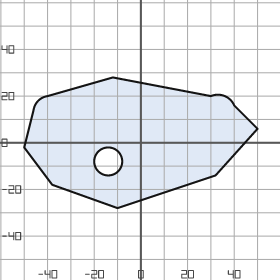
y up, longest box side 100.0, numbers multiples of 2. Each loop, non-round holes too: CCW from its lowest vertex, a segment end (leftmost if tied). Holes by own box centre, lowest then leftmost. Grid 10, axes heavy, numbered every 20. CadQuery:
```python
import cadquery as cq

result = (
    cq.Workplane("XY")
    .moveTo(-10.0, -28.0)
    .lineTo(32.0, -14.0)
    .lineTo(50.0, 6.0)
    .lineTo(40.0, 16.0)
    .threePointArc((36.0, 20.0), (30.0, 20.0))
    .lineTo(-12.0, 28.0)
    .lineTo(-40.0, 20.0)
    .threePointArc((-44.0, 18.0), (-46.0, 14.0))
    .lineTo(-50.0, -2.0)
    .lineTo(-38.0, -18.0)
    .close()
    .moveTo(-14.0, -8.0)
    .circle(6.0)
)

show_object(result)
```